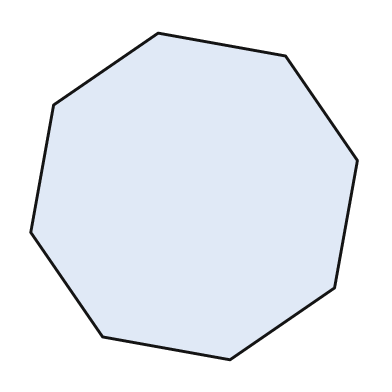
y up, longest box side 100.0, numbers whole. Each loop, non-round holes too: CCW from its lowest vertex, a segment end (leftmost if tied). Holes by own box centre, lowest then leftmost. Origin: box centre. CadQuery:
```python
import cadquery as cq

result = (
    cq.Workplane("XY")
    .moveTo(11.0, -50.0)
    .lineTo(43.0, -28.0)
    .lineTo(50.0, 11.0)
    .lineTo(28.0, 43.0)
    .lineTo(-11.0, 50.0)
    .lineTo(-43.0, 28.0)
    .lineTo(-50.0, -11.0)
    .lineTo(-28.0, -43.0)
    .close()
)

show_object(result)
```